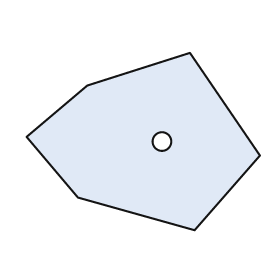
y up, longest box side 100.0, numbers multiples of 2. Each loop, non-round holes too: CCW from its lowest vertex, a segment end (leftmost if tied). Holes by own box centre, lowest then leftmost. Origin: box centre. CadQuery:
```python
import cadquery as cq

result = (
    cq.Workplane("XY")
    .moveTo(22.0, -38.0)
    .lineTo(50.0, -6.0)
    .lineTo(20.0, 38.0)
    .lineTo(-24.0, 24.0)
    .lineTo(-50.0, 2.0)
    .lineTo(-28.0, -24.0)
    .close()
    .moveTo(8.0, 0.0)
    .circle(4.0)
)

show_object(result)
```